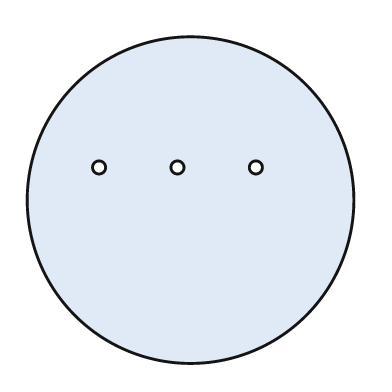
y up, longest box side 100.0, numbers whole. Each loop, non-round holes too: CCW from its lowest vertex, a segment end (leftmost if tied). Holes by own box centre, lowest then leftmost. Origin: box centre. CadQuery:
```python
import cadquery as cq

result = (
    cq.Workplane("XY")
    .moveTo(0.0, 0.0)
    .circle(50.0)
    .moveTo(-28.0, 10.0)
    .circle(2.0)
    .moveTo(-4.0, 10.0)
    .circle(2.0)
    .moveTo(20.0, 10.0)
    .circle(2.0)
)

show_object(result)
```